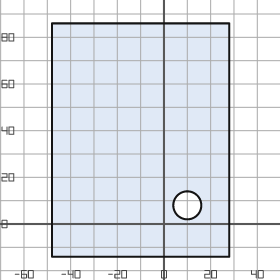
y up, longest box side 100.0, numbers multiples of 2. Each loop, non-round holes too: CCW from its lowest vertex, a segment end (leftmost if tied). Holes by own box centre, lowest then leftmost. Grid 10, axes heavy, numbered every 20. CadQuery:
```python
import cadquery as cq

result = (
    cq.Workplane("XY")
    .moveTo(-48.0, -14.0)
    .lineTo(28.0, -14.0)
    .lineTo(28.0, 86.0)
    .lineTo(-48.0, 86.0)
    .close()
    .moveTo(10.0, 8.0)
    .circle(6.0)
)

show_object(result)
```